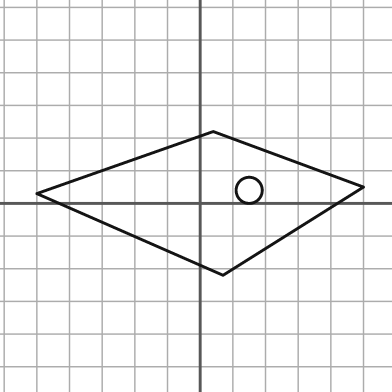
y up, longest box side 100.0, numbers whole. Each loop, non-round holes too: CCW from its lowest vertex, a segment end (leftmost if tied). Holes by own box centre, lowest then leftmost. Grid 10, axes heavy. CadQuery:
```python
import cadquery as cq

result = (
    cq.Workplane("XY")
    .moveTo(7.0, -22.0)
    .lineTo(50.0, 5.0)
    .lineTo(4.0, 22.0)
    .lineTo(-50.0, 3.0)
    .close()
    .moveTo(15.0, 4.0)
    .circle(4.0)
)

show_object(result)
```